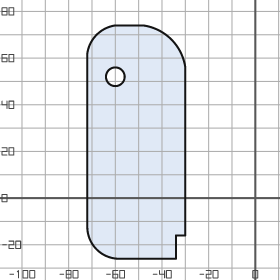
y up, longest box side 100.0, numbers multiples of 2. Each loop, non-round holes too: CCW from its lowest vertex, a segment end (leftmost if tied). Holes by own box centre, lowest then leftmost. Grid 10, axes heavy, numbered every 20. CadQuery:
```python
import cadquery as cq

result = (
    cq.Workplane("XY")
    .moveTo(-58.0, -26.0)
    .lineTo(-34.0, -26.0)
    .lineTo(-34.0, -16.0)
    .lineTo(-30.0, -16.0)
    .lineTo(-30.0, 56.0)
    .threePointArc((-36.0, 68.0), (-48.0, 74.0))
    .lineTo(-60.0, 74.0)
    .threePointArc((-68.0, 70.0), (-72.0, 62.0))
    .lineTo(-72.0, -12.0)
    .threePointArc((-68.0, -22.0), (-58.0, -26.0))
    .close()
    .moveTo(-60.0, 52.0)
    .circle(4.0)
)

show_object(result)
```